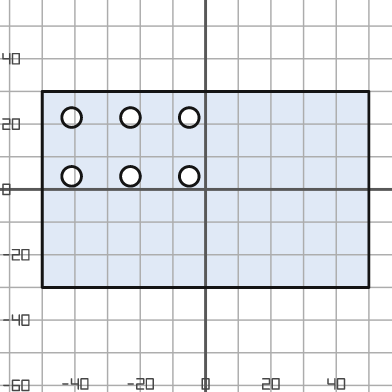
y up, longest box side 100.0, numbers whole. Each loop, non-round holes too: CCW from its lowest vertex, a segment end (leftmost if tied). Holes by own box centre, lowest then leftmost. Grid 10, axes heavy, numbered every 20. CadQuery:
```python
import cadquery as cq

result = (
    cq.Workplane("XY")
    .moveTo(-50.0, -30.0)
    .lineTo(50.0, -30.0)
    .lineTo(50.0, 30.0)
    .lineTo(-50.0, 30.0)
    .close()
    .moveTo(-41.0, 4.0)
    .circle(3.0)
    .moveTo(-23.0, 4.0)
    .circle(3.0)
    .moveTo(-5.0, 4.0)
    .circle(3.0)
    .moveTo(-41.0, 22.0)
    .circle(3.0)
    .moveTo(-23.0, 22.0)
    .circle(3.0)
    .moveTo(-5.0, 22.0)
    .circle(3.0)
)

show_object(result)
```